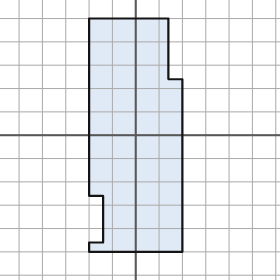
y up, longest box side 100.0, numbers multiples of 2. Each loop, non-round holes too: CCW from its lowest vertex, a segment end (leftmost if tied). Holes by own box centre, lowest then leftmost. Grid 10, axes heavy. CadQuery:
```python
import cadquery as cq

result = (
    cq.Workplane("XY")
    .moveTo(-20.0, -50.0)
    .lineTo(20.0, -50.0)
    .lineTo(20.0, 24.0)
    .lineTo(14.0, 24.0)
    .lineTo(14.0, 50.0)
    .lineTo(-20.0, 50.0)
    .lineTo(-20.0, -26.0)
    .lineTo(-14.0, -26.0)
    .lineTo(-14.0, -46.0)
    .lineTo(-20.0, -46.0)
    .close()
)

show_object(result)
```